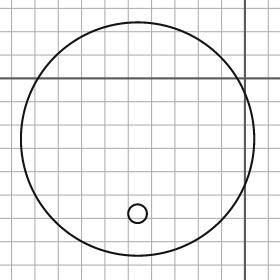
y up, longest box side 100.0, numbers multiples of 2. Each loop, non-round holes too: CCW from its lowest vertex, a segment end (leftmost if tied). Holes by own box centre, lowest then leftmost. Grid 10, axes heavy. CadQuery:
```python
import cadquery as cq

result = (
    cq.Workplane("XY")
    .moveTo(-46.0, -26.0)
    .circle(50.0)
    .moveTo(-46.0, -58.0)
    .circle(4.0)
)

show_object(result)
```